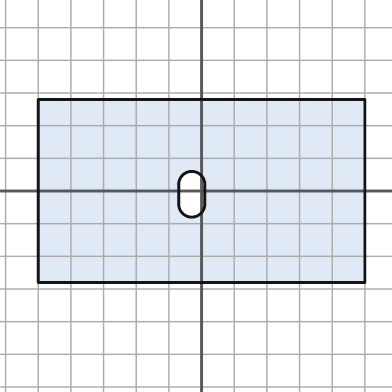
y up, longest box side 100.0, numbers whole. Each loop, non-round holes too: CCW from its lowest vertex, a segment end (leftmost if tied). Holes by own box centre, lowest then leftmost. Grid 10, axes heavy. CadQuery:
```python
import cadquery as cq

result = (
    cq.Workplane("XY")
    .moveTo(-50.0, -28.0)
    .lineTo(50.0, -28.0)
    .lineTo(50.0, 28.0)
    .lineTo(-50.0, 28.0)
    .close()
    .moveTo(-7.0, -4.0)
    .threePointArc((-3.0, -8.0), (1.0, -4.0))
    .lineTo(1.0, 2.0)
    .threePointArc((-3.0, 6.0), (-7.0, 2.0))
    .close()
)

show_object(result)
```